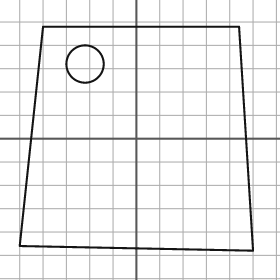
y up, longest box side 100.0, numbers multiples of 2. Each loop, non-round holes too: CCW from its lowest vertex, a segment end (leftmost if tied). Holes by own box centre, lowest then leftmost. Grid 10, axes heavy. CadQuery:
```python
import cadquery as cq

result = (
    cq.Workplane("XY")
    .moveTo(50.0, -48.0)
    .lineTo(44.0, 48.0)
    .lineTo(-40.0, 48.0)
    .lineTo(-50.0, -46.0)
    .close()
    .moveTo(-22.0, 32.0)
    .circle(8.0)
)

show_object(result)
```